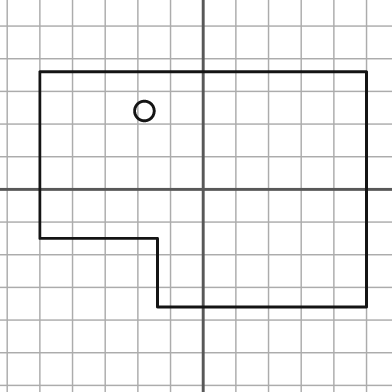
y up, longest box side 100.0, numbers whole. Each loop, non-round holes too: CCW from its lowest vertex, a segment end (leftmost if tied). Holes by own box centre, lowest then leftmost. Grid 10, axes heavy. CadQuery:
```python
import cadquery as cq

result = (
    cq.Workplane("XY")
    .moveTo(-14.0, -36.0)
    .lineTo(50.0, -36.0)
    .lineTo(50.0, 36.0)
    .lineTo(-50.0, 36.0)
    .lineTo(-50.0, -15.0)
    .lineTo(-14.0, -15.0)
    .close()
    .moveTo(-18.0, 24.0)
    .circle(3.0)
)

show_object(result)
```